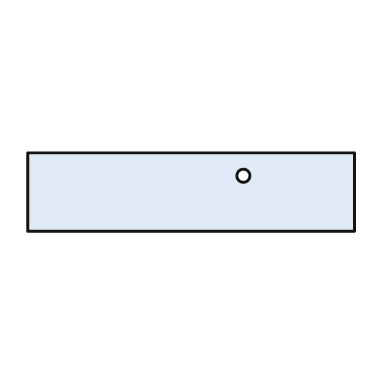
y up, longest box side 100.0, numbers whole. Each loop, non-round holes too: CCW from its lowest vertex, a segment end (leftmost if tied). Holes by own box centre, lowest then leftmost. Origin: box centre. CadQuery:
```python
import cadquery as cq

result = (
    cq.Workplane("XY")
    .moveTo(-50.0, -12.0)
    .lineTo(50.0, -12.0)
    .lineTo(50.0, 12.0)
    .lineTo(-50.0, 12.0)
    .close()
    .moveTo(16.0, 5.0)
    .circle(2.0)
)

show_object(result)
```